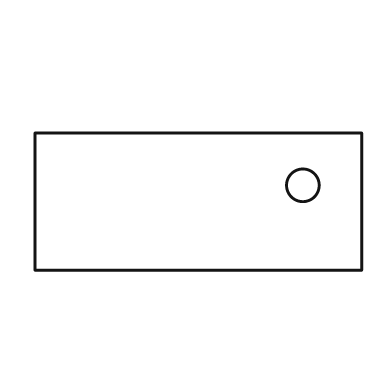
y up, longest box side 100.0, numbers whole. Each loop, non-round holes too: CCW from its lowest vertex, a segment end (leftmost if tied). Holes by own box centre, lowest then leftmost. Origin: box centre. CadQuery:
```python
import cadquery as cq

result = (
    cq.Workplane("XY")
    .moveTo(-50.0, -21.0)
    .lineTo(50.0, -21.0)
    .lineTo(50.0, 21.0)
    .lineTo(-50.0, 21.0)
    .close()
    .moveTo(32.0, 5.0)
    .circle(5.0)
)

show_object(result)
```